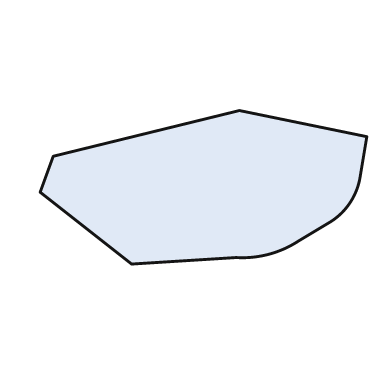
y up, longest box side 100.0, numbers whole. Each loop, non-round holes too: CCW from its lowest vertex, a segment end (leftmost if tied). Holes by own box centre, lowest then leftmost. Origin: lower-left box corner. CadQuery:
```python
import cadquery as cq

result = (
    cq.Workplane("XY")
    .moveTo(28.0, 0.0)
    .lineTo(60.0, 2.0)
    .threePointArc((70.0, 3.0), (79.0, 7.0))
    .lineTo(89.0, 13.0)
    .threePointArc((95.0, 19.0), (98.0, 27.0))
    .lineTo(100.0, 39.0)
    .lineTo(61.0, 47.0)
    .lineTo(4.0, 33.0)
    .lineTo(0.0, 22.0)
    .close()
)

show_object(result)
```